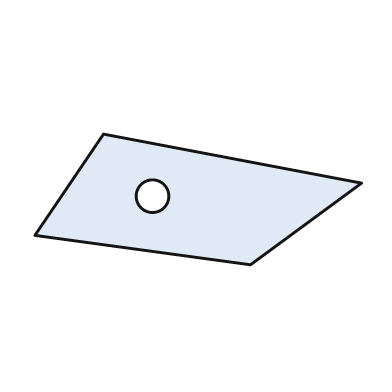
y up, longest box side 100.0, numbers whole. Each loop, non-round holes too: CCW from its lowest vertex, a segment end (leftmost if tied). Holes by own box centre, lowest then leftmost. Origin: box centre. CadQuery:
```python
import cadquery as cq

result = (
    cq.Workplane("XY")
    .moveTo(16.0, -20.0)
    .lineTo(50.0, 5.0)
    .lineTo(-29.0, 20.0)
    .lineTo(-50.0, -11.0)
    .close()
    .moveTo(-14.0, 1.0)
    .circle(5.0)
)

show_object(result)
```